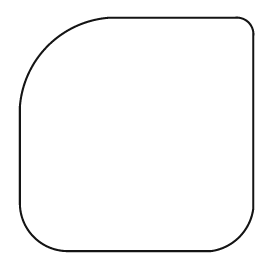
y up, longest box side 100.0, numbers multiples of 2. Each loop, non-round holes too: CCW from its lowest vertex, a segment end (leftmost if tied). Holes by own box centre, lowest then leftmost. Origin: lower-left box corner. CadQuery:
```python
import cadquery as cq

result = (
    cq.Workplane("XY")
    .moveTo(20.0, 0.0)
    .lineTo(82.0, 0.0)
    .threePointArc((94.0, 6.0), (100.0, 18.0))
    .lineTo(100.0, 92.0)
    .threePointArc((98.0, 98.0), (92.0, 100.0))
    .lineTo(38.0, 100.0)
    .threePointArc((12.0, 88.0), (0.0, 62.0))
    .lineTo(0.0, 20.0)
    .threePointArc((6.0, 6.0), (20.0, 0.0))
    .close()
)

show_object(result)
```